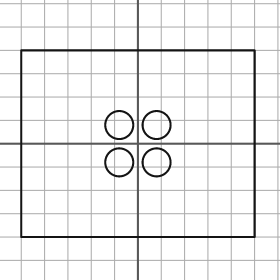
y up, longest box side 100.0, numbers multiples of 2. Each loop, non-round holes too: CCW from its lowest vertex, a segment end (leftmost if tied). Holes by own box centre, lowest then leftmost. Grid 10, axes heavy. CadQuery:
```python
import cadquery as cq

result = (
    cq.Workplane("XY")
    .moveTo(-50.0, -40.0)
    .lineTo(50.0, -40.0)
    .lineTo(50.0, 40.0)
    .lineTo(-50.0, 40.0)
    .close()
    .moveTo(-8.0, -8.0)
    .circle(6.0)
    .moveTo(8.0, -8.0)
    .circle(6.0)
    .moveTo(-8.0, 8.0)
    .circle(6.0)
    .moveTo(8.0, 8.0)
    .circle(6.0)
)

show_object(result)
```